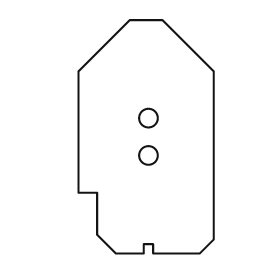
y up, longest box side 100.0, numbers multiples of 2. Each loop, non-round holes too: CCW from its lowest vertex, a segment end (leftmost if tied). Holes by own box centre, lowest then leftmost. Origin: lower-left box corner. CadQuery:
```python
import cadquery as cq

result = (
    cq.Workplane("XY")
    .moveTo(16.0, 0.0)
    .lineTo(28.0, 0.0)
    .lineTo(28.0, 4.0)
    .lineTo(32.0, 4.0)
    .lineTo(32.0, 0.0)
    .lineTo(52.0, 0.0)
    .lineTo(58.0, 6.0)
    .lineTo(58.0, 78.0)
    .lineTo(36.0, 100.0)
    .lineTo(22.0, 100.0)
    .lineTo(0.0, 78.0)
    .lineTo(0.0, 26.0)
    .lineTo(8.0, 26.0)
    .lineTo(8.0, 8.0)
    .close()
    .moveTo(30.0, 42.0)
    .circle(4.0)
    .moveTo(30.0, 58.0)
    .circle(4.0)
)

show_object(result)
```